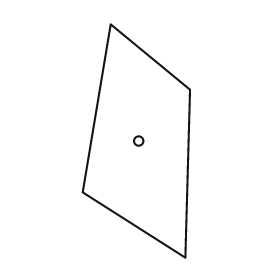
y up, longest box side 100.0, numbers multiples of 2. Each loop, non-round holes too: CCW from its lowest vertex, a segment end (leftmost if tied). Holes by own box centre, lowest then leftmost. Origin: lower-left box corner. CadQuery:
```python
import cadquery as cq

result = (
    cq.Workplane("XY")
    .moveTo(44.0, 0.0)
    .lineTo(46.0, 72.0)
    .lineTo(12.0, 100.0)
    .lineTo(0.0, 28.0)
    .close()
    .moveTo(24.0, 50.0)
    .circle(2.0)
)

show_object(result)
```